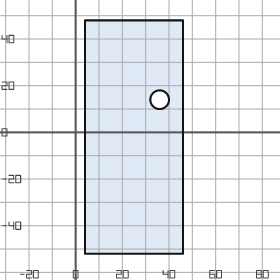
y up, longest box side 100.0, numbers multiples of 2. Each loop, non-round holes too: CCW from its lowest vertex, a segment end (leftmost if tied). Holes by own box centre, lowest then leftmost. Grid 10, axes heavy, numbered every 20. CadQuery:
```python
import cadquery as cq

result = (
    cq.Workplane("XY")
    .moveTo(4.0, -52.0)
    .lineTo(46.0, -52.0)
    .lineTo(46.0, 48.0)
    .lineTo(4.0, 48.0)
    .close()
    .moveTo(36.0, 14.0)
    .circle(4.0)
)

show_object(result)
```